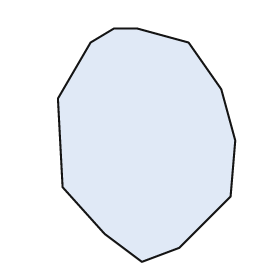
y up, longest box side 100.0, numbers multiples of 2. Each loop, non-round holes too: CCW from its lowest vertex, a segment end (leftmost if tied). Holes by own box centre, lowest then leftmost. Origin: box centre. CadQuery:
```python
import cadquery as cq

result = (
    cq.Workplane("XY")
    .moveTo(-2.0, -50.0)
    .lineTo(14.0, -44.0)
    .lineTo(36.0, -22.0)
    .lineTo(38.0, 2.0)
    .lineTo(32.0, 24.0)
    .lineTo(18.0, 44.0)
    .lineTo(-4.0, 50.0)
    .lineTo(-14.0, 50.0)
    .lineTo(-24.0, 44.0)
    .lineTo(-38.0, 20.0)
    .lineTo(-36.0, -18.0)
    .lineTo(-18.0, -38.0)
    .close()
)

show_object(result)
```